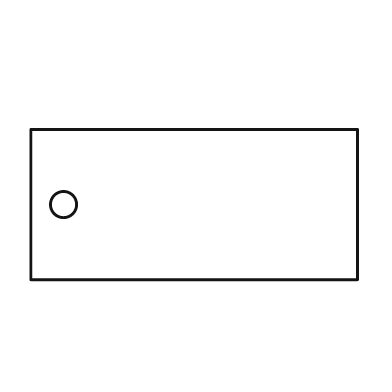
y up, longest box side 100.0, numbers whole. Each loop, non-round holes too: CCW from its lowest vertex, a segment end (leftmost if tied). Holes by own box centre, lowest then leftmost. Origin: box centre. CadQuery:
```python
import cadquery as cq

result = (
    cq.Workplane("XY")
    .moveTo(-50.0, -23.0)
    .lineTo(50.0, -23.0)
    .lineTo(50.0, 23.0)
    .lineTo(-50.0, 23.0)
    .close()
    .moveTo(-40.0, 0.0)
    .circle(4.0)
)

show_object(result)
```